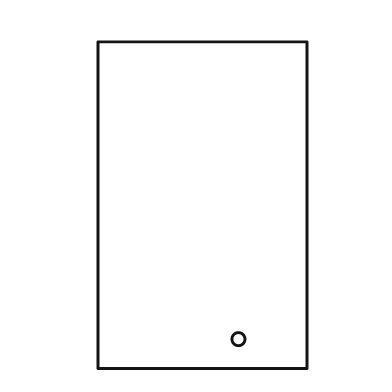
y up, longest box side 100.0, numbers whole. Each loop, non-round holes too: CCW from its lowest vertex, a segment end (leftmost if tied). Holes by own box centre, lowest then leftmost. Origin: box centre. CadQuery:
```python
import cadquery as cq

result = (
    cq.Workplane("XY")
    .moveTo(-32.0, -50.0)
    .lineTo(32.0, -50.0)
    .lineTo(32.0, 50.0)
    .lineTo(-32.0, 50.0)
    .close()
    .moveTo(11.0, -41.0)
    .circle(2.0)
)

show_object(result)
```